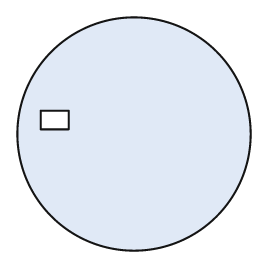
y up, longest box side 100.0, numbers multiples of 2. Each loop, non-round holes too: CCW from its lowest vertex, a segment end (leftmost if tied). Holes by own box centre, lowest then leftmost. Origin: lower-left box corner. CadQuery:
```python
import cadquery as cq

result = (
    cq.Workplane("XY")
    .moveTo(50.0, 50.0)
    .circle(50.0)
    .moveTo(10.0, 52.0)
    .lineTo(22.0, 52.0)
    .lineTo(22.0, 60.0)
    .lineTo(10.0, 60.0)
    .close()
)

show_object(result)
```